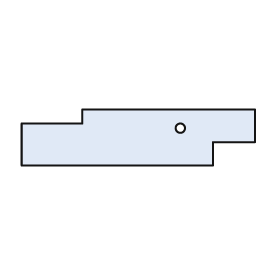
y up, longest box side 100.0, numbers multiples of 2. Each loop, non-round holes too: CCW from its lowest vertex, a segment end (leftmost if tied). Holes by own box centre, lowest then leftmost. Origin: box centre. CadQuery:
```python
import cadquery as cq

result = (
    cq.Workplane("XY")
    .moveTo(-50.0, -12.0)
    .lineTo(32.0, -12.0)
    .lineTo(32.0, -2.0)
    .lineTo(50.0, -2.0)
    .lineTo(50.0, 12.0)
    .lineTo(-24.0, 12.0)
    .lineTo(-24.0, 6.0)
    .lineTo(-50.0, 6.0)
    .close()
    .moveTo(18.0, 4.0)
    .circle(2.0)
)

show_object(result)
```